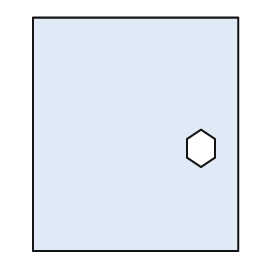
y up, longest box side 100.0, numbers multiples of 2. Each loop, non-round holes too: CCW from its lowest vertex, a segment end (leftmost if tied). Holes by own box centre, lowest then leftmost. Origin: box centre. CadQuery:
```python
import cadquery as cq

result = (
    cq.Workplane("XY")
    .moveTo(-44.0, -50.0)
    .lineTo(44.0, -50.0)
    .lineTo(44.0, 50.0)
    .lineTo(-44.0, 50.0)
    .close()
    .moveTo(28.0, -14.0)
    .lineTo(34.0, -10.0)
    .lineTo(34.0, -2.0)
    .lineTo(28.0, 2.0)
    .lineTo(22.0, -2.0)
    .lineTo(22.0, -10.0)
    .close()
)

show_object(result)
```